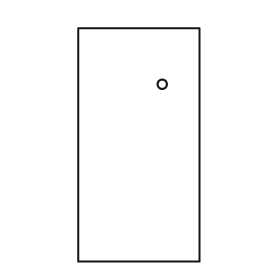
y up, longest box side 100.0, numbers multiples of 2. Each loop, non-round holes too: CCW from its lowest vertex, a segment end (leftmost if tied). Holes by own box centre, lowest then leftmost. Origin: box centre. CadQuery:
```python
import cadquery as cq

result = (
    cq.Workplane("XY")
    .moveTo(-26.0, -50.0)
    .lineTo(26.0, -50.0)
    .lineTo(26.0, 50.0)
    .lineTo(-26.0, 50.0)
    .close()
    .moveTo(10.0, 26.0)
    .circle(2.0)
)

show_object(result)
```